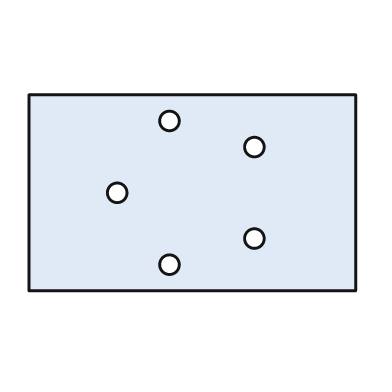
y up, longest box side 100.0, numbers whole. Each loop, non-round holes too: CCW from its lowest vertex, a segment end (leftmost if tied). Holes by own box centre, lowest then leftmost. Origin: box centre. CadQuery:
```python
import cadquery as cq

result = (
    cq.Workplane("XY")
    .moveTo(-50.0, -30.0)
    .lineTo(50.0, -30.0)
    .lineTo(50.0, 30.0)
    .lineTo(-50.0, 30.0)
    .close()
    .moveTo(-7.0, -22.0)
    .circle(3.0)
    .moveTo(19.0, -14.0)
    .circle(3.0)
    .moveTo(-23.0, 0.0)
    .circle(3.0)
    .moveTo(19.0, 14.0)
    .circle(3.0)
    .moveTo(-7.0, 22.0)
    .circle(3.0)
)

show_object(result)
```